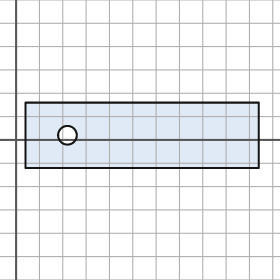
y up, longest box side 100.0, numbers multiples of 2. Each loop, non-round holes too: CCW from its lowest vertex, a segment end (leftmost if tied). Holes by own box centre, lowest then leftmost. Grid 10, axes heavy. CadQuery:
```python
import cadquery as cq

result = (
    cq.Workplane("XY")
    .moveTo(4.0, -12.0)
    .lineTo(104.0, -12.0)
    .lineTo(104.0, 16.0)
    .lineTo(4.0, 16.0)
    .close()
    .moveTo(22.0, 2.0)
    .circle(4.0)
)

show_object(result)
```